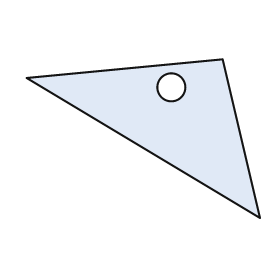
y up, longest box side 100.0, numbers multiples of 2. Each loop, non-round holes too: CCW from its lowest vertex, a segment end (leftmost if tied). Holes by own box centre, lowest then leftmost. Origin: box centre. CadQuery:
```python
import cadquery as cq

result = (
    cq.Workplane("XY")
    .moveTo(50.0, -34.0)
    .lineTo(34.0, 34.0)
    .lineTo(-50.0, 26.0)
    .close()
    .moveTo(12.0, 22.0)
    .circle(6.0)
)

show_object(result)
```